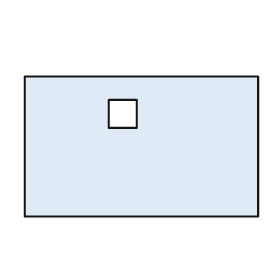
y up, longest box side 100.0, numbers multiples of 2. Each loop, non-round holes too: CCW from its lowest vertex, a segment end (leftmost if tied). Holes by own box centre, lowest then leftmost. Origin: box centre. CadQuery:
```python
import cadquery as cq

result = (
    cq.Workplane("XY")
    .moveTo(-50.0, -30.0)
    .lineTo(50.0, -30.0)
    .lineTo(50.0, 30.0)
    .lineTo(-50.0, 30.0)
    .close()
    .moveTo(-14.0, 8.0)
    .lineTo(-2.0, 8.0)
    .lineTo(-2.0, 20.0)
    .lineTo(-14.0, 20.0)
    .close()
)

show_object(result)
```